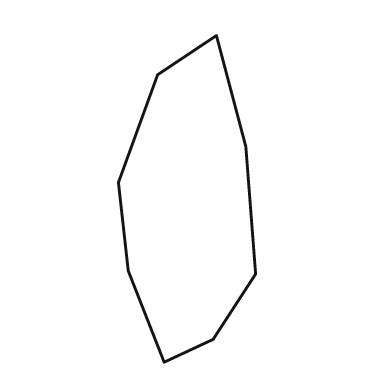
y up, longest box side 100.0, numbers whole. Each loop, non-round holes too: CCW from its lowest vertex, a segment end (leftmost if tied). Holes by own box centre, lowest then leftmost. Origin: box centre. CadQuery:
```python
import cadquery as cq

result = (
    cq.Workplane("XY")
    .moveTo(-7.0, -50.0)
    .lineTo(8.0, -43.0)
    .lineTo(21.0, -23.0)
    .lineTo(18.0, 16.0)
    .lineTo(9.0, 50.0)
    .lineTo(-9.0, 38.0)
    .lineTo(-21.0, 5.0)
    .lineTo(-18.0, -22.0)
    .close()
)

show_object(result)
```